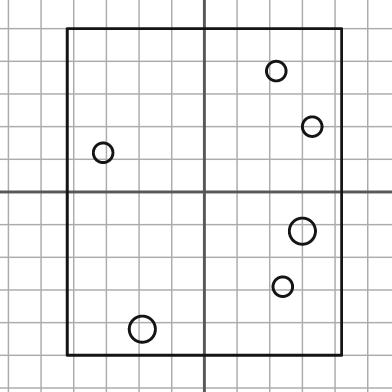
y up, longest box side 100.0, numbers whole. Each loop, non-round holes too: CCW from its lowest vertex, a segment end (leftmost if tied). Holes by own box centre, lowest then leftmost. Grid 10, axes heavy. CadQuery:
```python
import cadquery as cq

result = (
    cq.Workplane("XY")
    .moveTo(-42.0, -50.0)
    .lineTo(42.0, -50.0)
    .lineTo(42.0, 50.0)
    .lineTo(-42.0, 50.0)
    .close()
    .moveTo(-19.0, -42.0)
    .circle(4.0)
    .moveTo(24.0, -29.0)
    .circle(3.0)
    .moveTo(30.0, -12.0)
    .circle(4.0)
    .moveTo(-31.0, 12.0)
    .circle(3.0)
    .moveTo(33.0, 20.0)
    .circle(3.0)
    .moveTo(22.0, 37.0)
    .circle(3.0)
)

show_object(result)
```